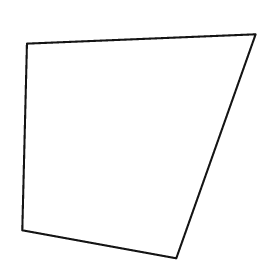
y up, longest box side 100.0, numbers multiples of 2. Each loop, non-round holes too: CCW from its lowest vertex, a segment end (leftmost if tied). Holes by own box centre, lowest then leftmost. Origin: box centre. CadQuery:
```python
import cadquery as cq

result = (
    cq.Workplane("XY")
    .moveTo(16.0, -48.0)
    .lineTo(50.0, 48.0)
    .lineTo(-48.0, 44.0)
    .lineTo(-50.0, -36.0)
    .close()
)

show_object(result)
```